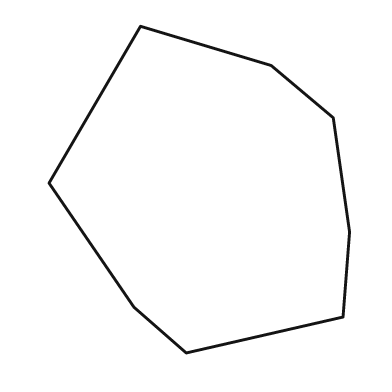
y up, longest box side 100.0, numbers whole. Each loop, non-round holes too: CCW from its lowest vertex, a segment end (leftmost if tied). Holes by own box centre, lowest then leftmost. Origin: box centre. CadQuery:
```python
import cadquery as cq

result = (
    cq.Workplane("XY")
    .moveTo(-4.0, -50.0)
    .lineTo(44.0, -39.0)
    .lineTo(46.0, -13.0)
    .lineTo(41.0, 22.0)
    .lineTo(22.0, 38.0)
    .lineTo(-18.0, 50.0)
    .lineTo(-46.0, 2.0)
    .lineTo(-20.0, -36.0)
    .close()
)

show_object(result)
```